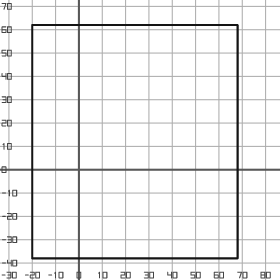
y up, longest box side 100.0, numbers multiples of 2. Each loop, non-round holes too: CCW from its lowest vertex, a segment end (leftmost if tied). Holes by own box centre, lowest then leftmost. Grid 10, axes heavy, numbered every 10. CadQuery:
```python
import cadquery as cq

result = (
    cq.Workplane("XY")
    .moveTo(-20.0, -38.0)
    .lineTo(68.0, -38.0)
    .lineTo(68.0, 62.0)
    .lineTo(-20.0, 62.0)
    .close()
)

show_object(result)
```